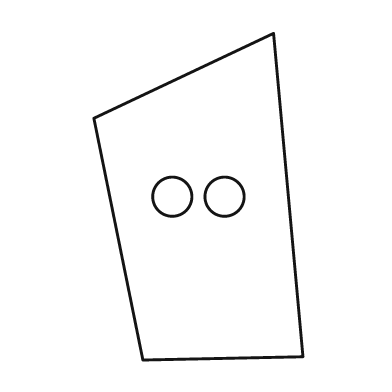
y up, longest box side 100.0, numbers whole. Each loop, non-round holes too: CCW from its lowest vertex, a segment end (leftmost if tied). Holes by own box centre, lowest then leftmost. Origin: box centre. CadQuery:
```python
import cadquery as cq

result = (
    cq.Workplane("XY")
    .moveTo(-17.0, -50.0)
    .lineTo(32.0, -49.0)
    .lineTo(23.0, 50.0)
    .lineTo(-32.0, 24.0)
    .close()
    .moveTo(-8.0, 0.0)
    .circle(6.0)
    .moveTo(8.0, 0.0)
    .circle(6.0)
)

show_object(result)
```